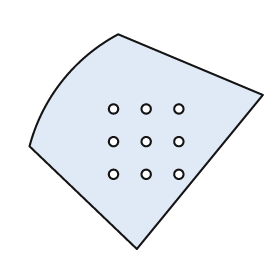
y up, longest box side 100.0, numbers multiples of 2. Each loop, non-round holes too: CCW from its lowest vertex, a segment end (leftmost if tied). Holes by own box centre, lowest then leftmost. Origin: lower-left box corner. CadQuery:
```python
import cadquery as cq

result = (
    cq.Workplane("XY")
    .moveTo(46.0, 0.0)
    .lineTo(100.0, 66.0)
    .lineTo(38.0, 92.0)
    .threePointArc((14.0, 72.0), (0.0, 44.0))
    .close()
    .moveTo(36.0, 32.0)
    .circle(2.0)
    .moveTo(50.0, 32.0)
    .circle(2.0)
    .moveTo(64.0, 32.0)
    .circle(2.0)
    .moveTo(36.0, 46.0)
    .circle(2.0)
    .moveTo(50.0, 46.0)
    .circle(2.0)
    .moveTo(64.0, 46.0)
    .circle(2.0)
    .moveTo(36.0, 60.0)
    .circle(2.0)
    .moveTo(50.0, 60.0)
    .circle(2.0)
    .moveTo(64.0, 60.0)
    .circle(2.0)
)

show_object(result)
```